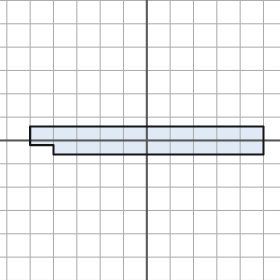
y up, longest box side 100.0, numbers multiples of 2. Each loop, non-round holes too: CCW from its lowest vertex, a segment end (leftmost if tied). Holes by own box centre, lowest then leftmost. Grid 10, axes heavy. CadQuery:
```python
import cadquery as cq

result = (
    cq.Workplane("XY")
    .moveTo(-40.0, -6.0)
    .lineTo(50.0, -6.0)
    .lineTo(50.0, 6.0)
    .lineTo(-50.0, 6.0)
    .lineTo(-50.0, -2.0)
    .lineTo(-40.0, -2.0)
    .close()
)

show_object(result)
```